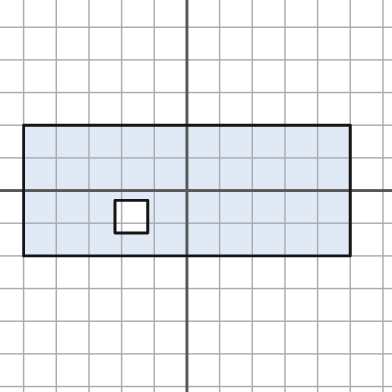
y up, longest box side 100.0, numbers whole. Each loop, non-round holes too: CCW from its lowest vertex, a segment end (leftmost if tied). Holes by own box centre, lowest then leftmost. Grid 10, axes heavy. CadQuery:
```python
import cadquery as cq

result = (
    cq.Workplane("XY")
    .moveTo(-50.0, -20.0)
    .lineTo(50.0, -20.0)
    .lineTo(50.0, 20.0)
    .lineTo(-50.0, 20.0)
    .close()
    .moveTo(-22.0, -13.0)
    .lineTo(-12.0, -13.0)
    .lineTo(-12.0, -3.0)
    .lineTo(-22.0, -3.0)
    .close()
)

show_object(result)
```